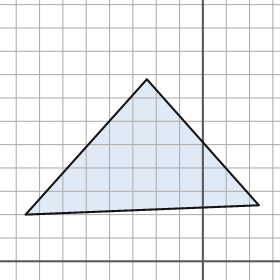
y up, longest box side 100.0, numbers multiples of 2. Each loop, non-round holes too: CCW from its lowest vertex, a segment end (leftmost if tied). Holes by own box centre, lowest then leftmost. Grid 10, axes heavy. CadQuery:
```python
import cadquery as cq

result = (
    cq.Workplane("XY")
    .moveTo(-76.0, 20.0)
    .lineTo(24.0, 24.0)
    .lineTo(-24.0, 78.0)
    .close()
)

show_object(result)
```